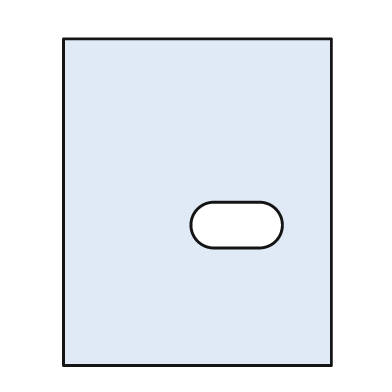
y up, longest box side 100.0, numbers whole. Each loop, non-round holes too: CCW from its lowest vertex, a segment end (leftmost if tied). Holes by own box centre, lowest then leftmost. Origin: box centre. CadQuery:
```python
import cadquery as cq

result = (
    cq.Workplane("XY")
    .moveTo(-41.0, -50.0)
    .lineTo(41.0, -50.0)
    .lineTo(41.0, 50.0)
    .lineTo(-41.0, 50.0)
    .close()
    .moveTo(5.0, -14.0)
    .lineTo(19.0, -14.0)
    .threePointArc((26.0, -7.0), (19.0, 0.0))
    .lineTo(5.0, 0.0)
    .threePointArc((-2.0, -7.0), (5.0, -14.0))
    .close()
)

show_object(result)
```